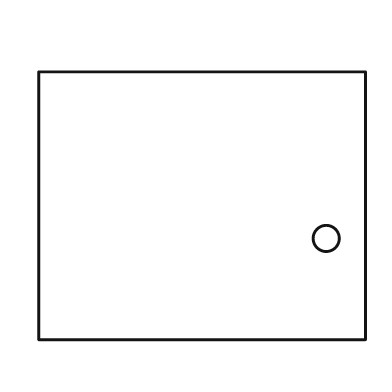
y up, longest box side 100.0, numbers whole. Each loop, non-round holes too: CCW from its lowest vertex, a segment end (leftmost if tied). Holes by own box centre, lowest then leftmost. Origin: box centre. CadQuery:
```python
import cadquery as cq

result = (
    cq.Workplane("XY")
    .moveTo(-50.0, -41.0)
    .lineTo(50.0, -41.0)
    .lineTo(50.0, 41.0)
    .lineTo(-50.0, 41.0)
    .close()
    .moveTo(38.0, -10.0)
    .circle(4.0)
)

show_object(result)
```